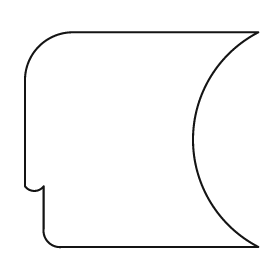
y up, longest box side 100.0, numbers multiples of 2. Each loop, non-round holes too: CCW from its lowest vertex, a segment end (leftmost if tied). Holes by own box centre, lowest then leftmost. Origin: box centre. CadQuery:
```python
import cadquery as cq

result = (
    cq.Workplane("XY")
    .moveTo(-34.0, -46.0)
    .lineTo(50.0, -46.0)
    .threePointArc((22.0, 0.0), (50.0, 46.0))
    .lineTo(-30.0, 46.0)
    .threePointArc((-44.0, 40.0), (-50.0, 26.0))
    .lineTo(-50.0, -20.0)
    .threePointArc((-46.0, -22.0), (-42.0, -20.0))
    .lineTo(-42.0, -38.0)
    .threePointArc((-40.0, -44.0), (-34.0, -46.0))
    .close()
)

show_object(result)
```